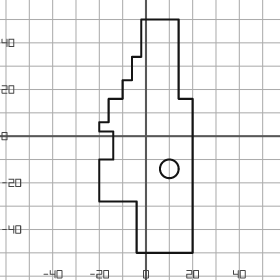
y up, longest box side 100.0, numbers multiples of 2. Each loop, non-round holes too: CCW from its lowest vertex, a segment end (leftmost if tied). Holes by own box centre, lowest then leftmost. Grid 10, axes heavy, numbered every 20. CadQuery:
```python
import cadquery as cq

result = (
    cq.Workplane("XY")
    .moveTo(-4.0, -50.0)
    .lineTo(20.0, -50.0)
    .lineTo(20.0, 16.0)
    .lineTo(14.0, 16.0)
    .lineTo(14.0, 50.0)
    .lineTo(-2.0, 50.0)
    .lineTo(-2.0, 34.0)
    .lineTo(-6.0, 34.0)
    .lineTo(-6.0, 24.0)
    .lineTo(-10.0, 24.0)
    .lineTo(-10.0, 16.0)
    .lineTo(-16.0, 16.0)
    .lineTo(-16.0, 6.0)
    .lineTo(-20.0, 6.0)
    .lineTo(-20.0, 2.0)
    .lineTo(-14.0, 2.0)
    .lineTo(-14.0, -10.0)
    .lineTo(-20.0, -10.0)
    .lineTo(-20.0, -28.0)
    .lineTo(-4.0, -28.0)
    .close()
    .moveTo(10.0, -14.0)
    .circle(4.0)
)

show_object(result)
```